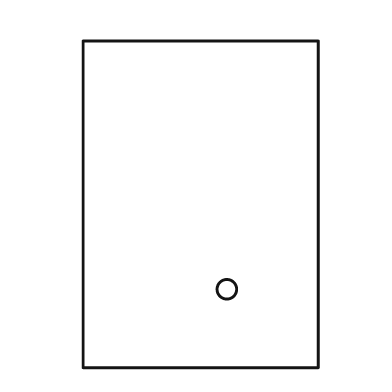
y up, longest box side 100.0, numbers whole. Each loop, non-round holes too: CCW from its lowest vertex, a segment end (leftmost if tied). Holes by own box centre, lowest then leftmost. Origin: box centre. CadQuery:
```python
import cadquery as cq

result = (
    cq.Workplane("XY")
    .moveTo(-36.0, -50.0)
    .lineTo(36.0, -50.0)
    .lineTo(36.0, 50.0)
    .lineTo(-36.0, 50.0)
    .close()
    .moveTo(8.0, -26.0)
    .circle(3.0)
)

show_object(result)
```